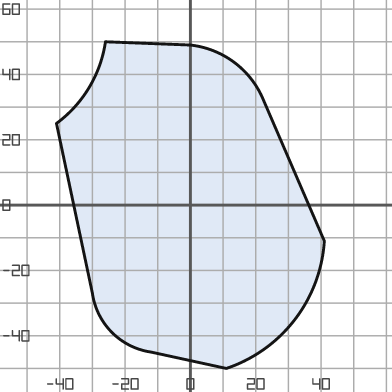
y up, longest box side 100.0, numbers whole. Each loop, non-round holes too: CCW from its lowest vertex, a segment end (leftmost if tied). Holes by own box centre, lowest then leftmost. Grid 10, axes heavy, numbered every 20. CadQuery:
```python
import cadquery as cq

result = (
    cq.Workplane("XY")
    .moveTo(11.0, -50.0)
    .threePointArc((32.0, -35.0), (41.0, -11.0))
    .lineTo(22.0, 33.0)
    .threePointArc((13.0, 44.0), (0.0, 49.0))
    .lineTo(-26.0, 50.0)
    .threePointArc((-31.0, 36.0), (-41.0, 25.0))
    .lineTo(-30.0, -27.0)
    .threePointArc((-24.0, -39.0), (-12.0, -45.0))
    .close()
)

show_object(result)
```